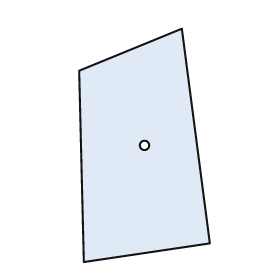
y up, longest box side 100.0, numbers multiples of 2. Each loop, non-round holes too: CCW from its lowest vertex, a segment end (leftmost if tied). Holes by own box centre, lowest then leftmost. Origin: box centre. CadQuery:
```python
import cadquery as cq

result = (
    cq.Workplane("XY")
    .moveTo(-26.0, -50.0)
    .lineTo(28.0, -42.0)
    .lineTo(16.0, 50.0)
    .lineTo(-28.0, 32.0)
    .close()
    .moveTo(0.0, 0.0)
    .circle(2.0)
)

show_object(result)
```